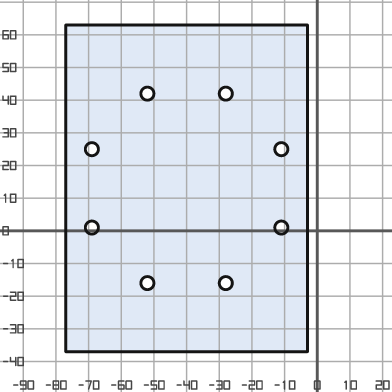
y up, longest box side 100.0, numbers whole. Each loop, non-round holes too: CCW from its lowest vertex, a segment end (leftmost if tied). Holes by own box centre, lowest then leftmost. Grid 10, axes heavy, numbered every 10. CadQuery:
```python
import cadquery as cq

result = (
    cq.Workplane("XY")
    .moveTo(-77.0, -37.0)
    .lineTo(-3.0, -37.0)
    .lineTo(-3.0, 63.0)
    .lineTo(-77.0, 63.0)
    .close()
    .moveTo(-52.0, -16.0)
    .circle(2.0)
    .moveTo(-28.0, -16.0)
    .circle(2.0)
    .moveTo(-69.0, 1.0)
    .circle(2.0)
    .moveTo(-11.0, 1.0)
    .circle(2.0)
    .moveTo(-69.0, 25.0)
    .circle(2.0)
    .moveTo(-11.0, 25.0)
    .circle(2.0)
    .moveTo(-52.0, 42.0)
    .circle(2.0)
    .moveTo(-28.0, 42.0)
    .circle(2.0)
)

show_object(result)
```